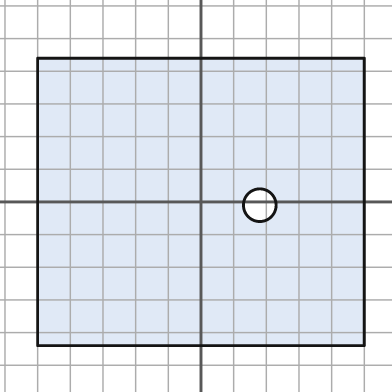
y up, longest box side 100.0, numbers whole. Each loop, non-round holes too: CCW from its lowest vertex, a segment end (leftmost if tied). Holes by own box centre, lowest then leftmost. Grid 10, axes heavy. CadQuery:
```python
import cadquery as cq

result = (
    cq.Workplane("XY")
    .moveTo(-50.0, -44.0)
    .lineTo(50.0, -44.0)
    .lineTo(50.0, 44.0)
    .lineTo(-50.0, 44.0)
    .close()
    .moveTo(18.0, -1.0)
    .circle(5.0)
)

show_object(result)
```